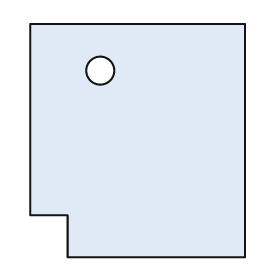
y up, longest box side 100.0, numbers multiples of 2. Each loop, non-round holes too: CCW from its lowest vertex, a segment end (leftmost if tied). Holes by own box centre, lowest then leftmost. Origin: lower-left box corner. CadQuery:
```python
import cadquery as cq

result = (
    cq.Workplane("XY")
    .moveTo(16.0, 0.0)
    .lineTo(92.0, 0.0)
    .lineTo(92.0, 100.0)
    .lineTo(0.0, 100.0)
    .lineTo(0.0, 18.0)
    .lineTo(16.0, 18.0)
    .close()
    .moveTo(30.0, 80.0)
    .circle(6.0)
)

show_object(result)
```